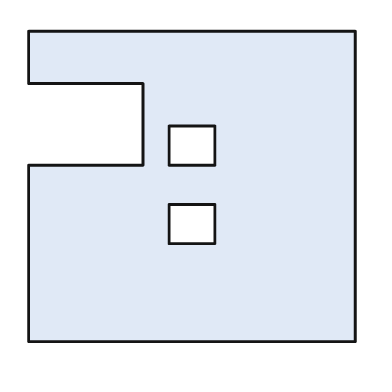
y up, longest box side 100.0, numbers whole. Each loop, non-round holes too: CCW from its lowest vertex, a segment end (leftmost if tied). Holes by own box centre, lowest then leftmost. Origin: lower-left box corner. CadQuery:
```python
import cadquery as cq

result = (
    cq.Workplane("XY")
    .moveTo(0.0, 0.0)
    .lineTo(100.0, 0.0)
    .lineTo(100.0, 95.0)
    .lineTo(0.0, 95.0)
    .lineTo(0.0, 79.0)
    .lineTo(35.0, 79.0)
    .lineTo(35.0, 54.0)
    .lineTo(0.0, 54.0)
    .close()
    .moveTo(43.0, 30.0)
    .lineTo(57.0, 30.0)
    .lineTo(57.0, 42.0)
    .lineTo(43.0, 42.0)
    .close()
    .moveTo(43.0, 54.0)
    .lineTo(57.0, 54.0)
    .lineTo(57.0, 66.0)
    .lineTo(43.0, 66.0)
    .close()
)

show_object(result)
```